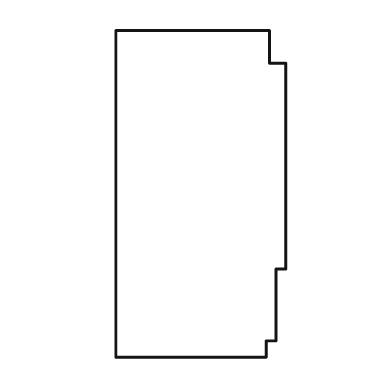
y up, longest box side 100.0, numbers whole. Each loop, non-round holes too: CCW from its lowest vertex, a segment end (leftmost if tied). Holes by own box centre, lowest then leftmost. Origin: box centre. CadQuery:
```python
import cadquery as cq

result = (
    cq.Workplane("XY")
    .moveTo(-26.0, -50.0)
    .lineTo(20.0, -50.0)
    .lineTo(20.0, -45.0)
    .lineTo(23.0, -45.0)
    .lineTo(23.0, -23.0)
    .lineTo(26.0, -23.0)
    .lineTo(26.0, 40.0)
    .lineTo(21.0, 40.0)
    .lineTo(21.0, 50.0)
    .lineTo(-26.0, 50.0)
    .close()
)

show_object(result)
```